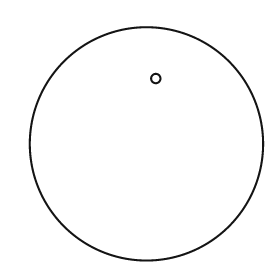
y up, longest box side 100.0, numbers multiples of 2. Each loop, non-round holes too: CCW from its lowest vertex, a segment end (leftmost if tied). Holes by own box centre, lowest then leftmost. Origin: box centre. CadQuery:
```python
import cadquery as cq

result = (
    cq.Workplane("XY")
    .moveTo(0.0, 0.0)
    .circle(50.0)
    .moveTo(4.0, 28.0)
    .circle(2.0)
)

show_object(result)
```